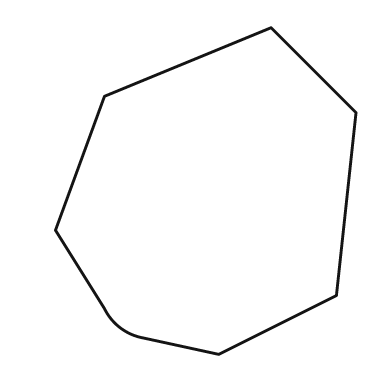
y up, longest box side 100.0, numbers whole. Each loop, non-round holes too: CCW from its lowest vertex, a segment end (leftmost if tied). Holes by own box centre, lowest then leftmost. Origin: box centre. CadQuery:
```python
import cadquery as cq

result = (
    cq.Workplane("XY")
    .moveTo(4.0, -50.0)
    .lineTo(40.0, -32.0)
    .lineTo(46.0, 24.0)
    .lineTo(20.0, 50.0)
    .lineTo(-31.0, 29.0)
    .lineTo(-46.0, -12.0)
    .lineTo(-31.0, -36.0)
    .threePointArc((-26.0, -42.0), (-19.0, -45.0))
    .close()
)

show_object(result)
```